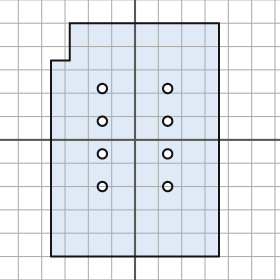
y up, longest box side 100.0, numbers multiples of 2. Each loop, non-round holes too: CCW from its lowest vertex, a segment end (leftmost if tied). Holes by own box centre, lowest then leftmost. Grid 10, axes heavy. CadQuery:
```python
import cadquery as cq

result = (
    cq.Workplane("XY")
    .moveTo(-36.0, -50.0)
    .lineTo(36.0, -50.0)
    .lineTo(36.0, 50.0)
    .lineTo(-28.0, 50.0)
    .lineTo(-28.0, 34.0)
    .lineTo(-36.0, 34.0)
    .close()
    .moveTo(-14.0, -20.0)
    .circle(2.0)
    .moveTo(14.0, -20.0)
    .circle(2.0)
    .moveTo(-14.0, -6.0)
    .circle(2.0)
    .moveTo(14.0, -6.0)
    .circle(2.0)
    .moveTo(-14.0, 8.0)
    .circle(2.0)
    .moveTo(14.0, 8.0)
    .circle(2.0)
    .moveTo(-14.0, 22.0)
    .circle(2.0)
    .moveTo(14.0, 22.0)
    .circle(2.0)
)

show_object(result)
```